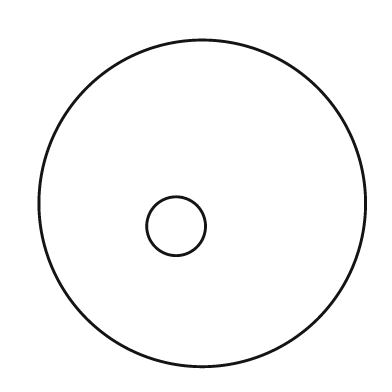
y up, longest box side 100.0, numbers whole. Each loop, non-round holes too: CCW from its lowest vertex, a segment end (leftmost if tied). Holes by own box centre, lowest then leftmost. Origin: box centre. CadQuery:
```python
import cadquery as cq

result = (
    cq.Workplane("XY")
    .moveTo(0.0, 0.0)
    .circle(50.0)
    .moveTo(-8.0, -7.0)
    .circle(9.0)
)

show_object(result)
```